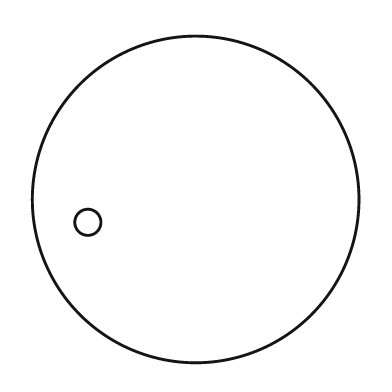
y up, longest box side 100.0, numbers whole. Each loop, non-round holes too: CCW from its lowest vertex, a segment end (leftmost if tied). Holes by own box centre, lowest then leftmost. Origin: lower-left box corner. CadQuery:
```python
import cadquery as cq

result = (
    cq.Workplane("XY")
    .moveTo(50.0, 50.0)
    .circle(50.0)
    .moveTo(17.0, 43.0)
    .circle(4.0)
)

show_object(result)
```